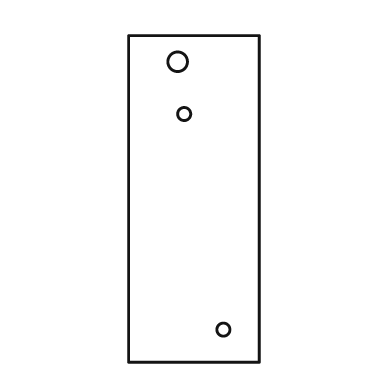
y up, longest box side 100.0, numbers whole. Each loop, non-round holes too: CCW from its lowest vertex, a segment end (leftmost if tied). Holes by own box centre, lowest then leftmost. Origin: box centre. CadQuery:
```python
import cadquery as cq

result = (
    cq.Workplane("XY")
    .moveTo(-20.0, -50.0)
    .lineTo(20.0, -50.0)
    .lineTo(20.0, 50.0)
    .lineTo(-20.0, 50.0)
    .close()
    .moveTo(9.0, -40.0)
    .circle(2.0)
    .moveTo(-3.0, 26.0)
    .circle(2.0)
    .moveTo(-5.0, 42.0)
    .circle(3.0)
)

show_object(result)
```